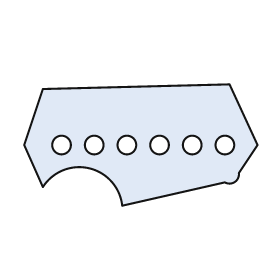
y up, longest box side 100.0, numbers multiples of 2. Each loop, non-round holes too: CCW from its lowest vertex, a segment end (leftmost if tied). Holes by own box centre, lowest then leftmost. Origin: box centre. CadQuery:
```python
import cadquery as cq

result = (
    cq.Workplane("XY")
    .moveTo(-8.0, -26.0)
    .lineTo(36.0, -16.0)
    .threePointArc((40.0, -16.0), (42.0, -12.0))
    .lineTo(50.0, 0.0)
    .lineTo(38.0, 26.0)
    .lineTo(-42.0, 24.0)
    .lineTo(-50.0, 0.0)
    .lineTo(-42.0, -18.0)
    .threePointArc((-22.0, -10.0), (-8.0, -26.0))
    .close()
    .moveTo(-34.0, 0.0)
    .circle(4.0)
    .moveTo(-20.0, 0.0)
    .circle(4.0)
    .moveTo(-6.0, 0.0)
    .circle(4.0)
    .moveTo(8.0, 0.0)
    .circle(4.0)
    .moveTo(22.0, 0.0)
    .circle(4.0)
    .moveTo(36.0, 0.0)
    .circle(4.0)
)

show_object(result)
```